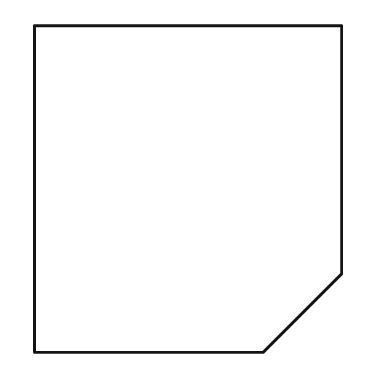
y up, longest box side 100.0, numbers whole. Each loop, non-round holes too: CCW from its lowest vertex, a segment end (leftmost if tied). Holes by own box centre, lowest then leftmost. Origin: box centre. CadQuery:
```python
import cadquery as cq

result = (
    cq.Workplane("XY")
    .moveTo(-47.0, -50.0)
    .lineTo(23.0, -50.0)
    .lineTo(47.0, -26.0)
    .lineTo(47.0, 50.0)
    .lineTo(-47.0, 50.0)
    .close()
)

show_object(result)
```